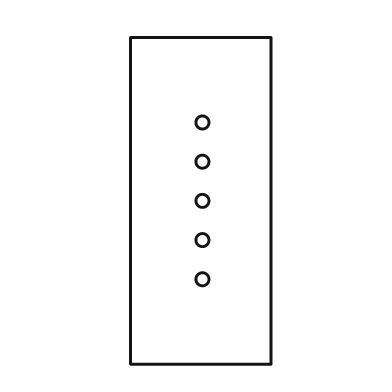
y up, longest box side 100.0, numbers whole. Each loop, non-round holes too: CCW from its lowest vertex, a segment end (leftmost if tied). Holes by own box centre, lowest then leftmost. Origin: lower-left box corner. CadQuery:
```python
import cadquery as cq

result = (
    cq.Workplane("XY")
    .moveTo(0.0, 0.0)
    .lineTo(43.0, 0.0)
    .lineTo(43.0, 100.0)
    .lineTo(0.0, 100.0)
    .close()
    .moveTo(22.0, 26.0)
    .circle(2.0)
    .moveTo(22.0, 38.0)
    .circle(2.0)
    .moveTo(22.0, 50.0)
    .circle(2.0)
    .moveTo(22.0, 62.0)
    .circle(2.0)
    .moveTo(22.0, 74.0)
    .circle(2.0)
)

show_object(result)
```